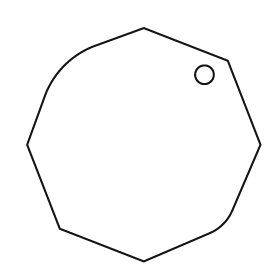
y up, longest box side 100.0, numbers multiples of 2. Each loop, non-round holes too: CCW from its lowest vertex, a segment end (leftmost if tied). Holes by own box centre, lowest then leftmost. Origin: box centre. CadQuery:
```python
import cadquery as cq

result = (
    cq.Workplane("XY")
    .moveTo(0.0, -50.0)
    .lineTo(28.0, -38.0)
    .threePointArc((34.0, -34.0), (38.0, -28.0))
    .lineTo(50.0, 0.0)
    .lineTo(36.0, 36.0)
    .lineTo(0.0, 50.0)
    .lineTo(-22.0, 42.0)
    .threePointArc((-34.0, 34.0), (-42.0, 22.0))
    .lineTo(-50.0, 0.0)
    .lineTo(-36.0, -36.0)
    .close()
    .moveTo(26.0, 30.0)
    .circle(4.0)
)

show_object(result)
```